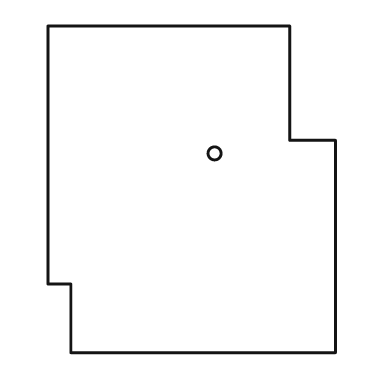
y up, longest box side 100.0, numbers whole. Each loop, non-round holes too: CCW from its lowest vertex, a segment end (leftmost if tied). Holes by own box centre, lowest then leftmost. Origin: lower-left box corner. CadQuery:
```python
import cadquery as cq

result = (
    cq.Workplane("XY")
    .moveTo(7.0, 0.0)
    .lineTo(88.0, 0.0)
    .lineTo(88.0, 65.0)
    .lineTo(74.0, 65.0)
    .lineTo(74.0, 100.0)
    .lineTo(0.0, 100.0)
    .lineTo(0.0, 21.0)
    .lineTo(7.0, 21.0)
    .close()
    .moveTo(51.0, 61.0)
    .circle(2.0)
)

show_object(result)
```